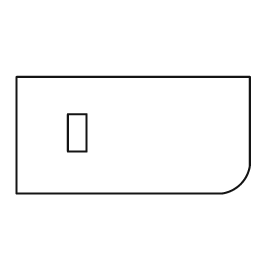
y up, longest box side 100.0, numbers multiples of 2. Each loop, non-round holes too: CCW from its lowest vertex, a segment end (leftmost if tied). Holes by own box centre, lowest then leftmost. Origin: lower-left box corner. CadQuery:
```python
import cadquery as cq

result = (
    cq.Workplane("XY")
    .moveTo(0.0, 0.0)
    .lineTo(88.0, 0.0)
    .threePointArc((96.0, 4.0), (100.0, 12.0))
    .lineTo(100.0, 50.0)
    .lineTo(0.0, 50.0)
    .close()
    .moveTo(22.0, 18.0)
    .lineTo(30.0, 18.0)
    .lineTo(30.0, 34.0)
    .lineTo(22.0, 34.0)
    .close()
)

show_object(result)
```